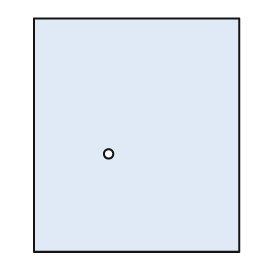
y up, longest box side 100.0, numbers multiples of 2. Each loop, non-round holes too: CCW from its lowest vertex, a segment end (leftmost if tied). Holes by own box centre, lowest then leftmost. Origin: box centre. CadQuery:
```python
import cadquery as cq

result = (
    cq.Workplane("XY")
    .moveTo(-44.0, -50.0)
    .lineTo(44.0, -50.0)
    .lineTo(44.0, 50.0)
    .lineTo(-44.0, 50.0)
    .close()
    .moveTo(-12.0, -8.0)
    .circle(2.0)
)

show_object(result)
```